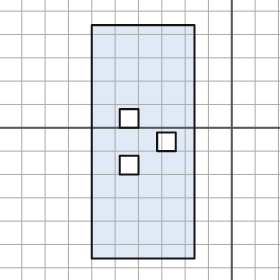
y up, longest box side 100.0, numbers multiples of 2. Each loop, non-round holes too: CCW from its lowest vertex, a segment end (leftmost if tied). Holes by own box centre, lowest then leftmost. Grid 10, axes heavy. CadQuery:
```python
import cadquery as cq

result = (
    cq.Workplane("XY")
    .moveTo(-60.0, -56.0)
    .lineTo(-16.0, -56.0)
    .lineTo(-16.0, 44.0)
    .lineTo(-60.0, 44.0)
    .close()
    .moveTo(-48.0, -20.0)
    .lineTo(-40.0, -20.0)
    .lineTo(-40.0, -12.0)
    .lineTo(-48.0, -12.0)
    .close()
    .moveTo(-32.0, -10.0)
    .lineTo(-24.0, -10.0)
    .lineTo(-24.0, -2.0)
    .lineTo(-32.0, -2.0)
    .close()
    .moveTo(-48.0, 0.0)
    .lineTo(-40.0, 0.0)
    .lineTo(-40.0, 8.0)
    .lineTo(-48.0, 8.0)
    .close()
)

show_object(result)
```